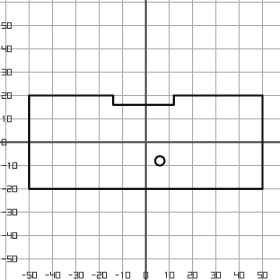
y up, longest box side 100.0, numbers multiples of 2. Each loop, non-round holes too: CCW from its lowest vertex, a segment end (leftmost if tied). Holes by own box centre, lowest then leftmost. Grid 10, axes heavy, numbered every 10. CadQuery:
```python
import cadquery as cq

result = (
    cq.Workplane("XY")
    .moveTo(-50.0, -20.0)
    .lineTo(50.0, -20.0)
    .lineTo(50.0, 20.0)
    .lineTo(12.0, 20.0)
    .lineTo(12.0, 16.0)
    .lineTo(-14.0, 16.0)
    .lineTo(-14.0, 20.0)
    .lineTo(-50.0, 20.0)
    .close()
    .moveTo(6.0, -8.0)
    .circle(2.0)
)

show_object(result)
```